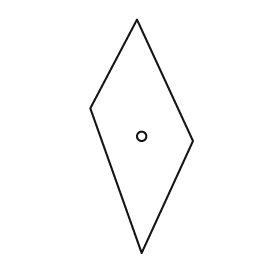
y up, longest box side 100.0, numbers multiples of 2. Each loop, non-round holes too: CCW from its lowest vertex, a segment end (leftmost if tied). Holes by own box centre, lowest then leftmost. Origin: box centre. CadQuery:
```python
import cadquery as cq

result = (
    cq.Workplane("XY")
    .moveTo(0.0, -50.0)
    .lineTo(22.0, -2.0)
    .lineTo(-2.0, 50.0)
    .lineTo(-22.0, 12.0)
    .close()
    .moveTo(0.0, 0.0)
    .circle(2.0)
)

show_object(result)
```